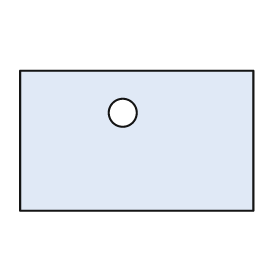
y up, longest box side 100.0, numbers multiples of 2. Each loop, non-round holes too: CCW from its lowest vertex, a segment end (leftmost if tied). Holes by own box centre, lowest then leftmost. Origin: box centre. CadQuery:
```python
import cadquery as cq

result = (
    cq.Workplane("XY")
    .moveTo(-50.0, -30.0)
    .lineTo(50.0, -30.0)
    .lineTo(50.0, 30.0)
    .lineTo(-50.0, 30.0)
    .close()
    .moveTo(-6.0, 12.0)
    .circle(6.0)
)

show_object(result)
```